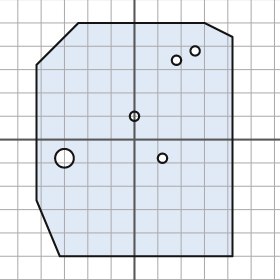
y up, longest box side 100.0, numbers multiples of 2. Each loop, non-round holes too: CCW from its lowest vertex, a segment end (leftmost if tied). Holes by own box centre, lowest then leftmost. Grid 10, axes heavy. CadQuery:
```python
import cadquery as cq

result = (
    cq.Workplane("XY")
    .moveTo(-32.0, -50.0)
    .lineTo(42.0, -50.0)
    .lineTo(42.0, 44.0)
    .lineTo(30.0, 50.0)
    .lineTo(-24.0, 50.0)
    .lineTo(-42.0, 32.0)
    .lineTo(-42.0, -26.0)
    .close()
    .moveTo(-30.0, -8.0)
    .circle(4.0)
    .moveTo(12.0, -8.0)
    .circle(2.0)
    .moveTo(0.0, 10.0)
    .circle(2.0)
    .moveTo(18.0, 34.0)
    .circle(2.0)
    .moveTo(26.0, 38.0)
    .circle(2.0)
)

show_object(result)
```